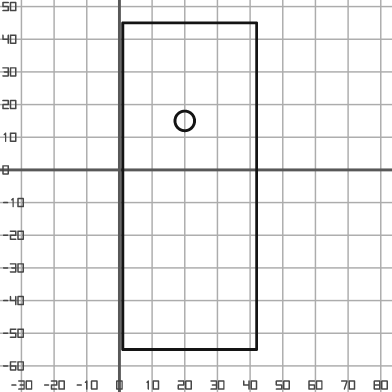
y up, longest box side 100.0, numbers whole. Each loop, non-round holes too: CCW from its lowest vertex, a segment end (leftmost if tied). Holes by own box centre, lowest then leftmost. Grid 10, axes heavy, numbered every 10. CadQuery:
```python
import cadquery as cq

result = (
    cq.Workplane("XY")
    .moveTo(1.0, -55.0)
    .lineTo(42.0, -55.0)
    .lineTo(42.0, 45.0)
    .lineTo(1.0, 45.0)
    .close()
    .moveTo(20.0, 15.0)
    .circle(3.0)
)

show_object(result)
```